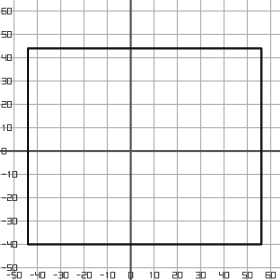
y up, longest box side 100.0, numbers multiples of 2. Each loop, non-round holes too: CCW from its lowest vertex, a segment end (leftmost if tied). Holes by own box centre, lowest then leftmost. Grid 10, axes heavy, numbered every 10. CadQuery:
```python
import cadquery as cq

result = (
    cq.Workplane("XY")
    .moveTo(-44.0, -40.0)
    .lineTo(56.0, -40.0)
    .lineTo(56.0, 44.0)
    .lineTo(-44.0, 44.0)
    .close()
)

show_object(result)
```